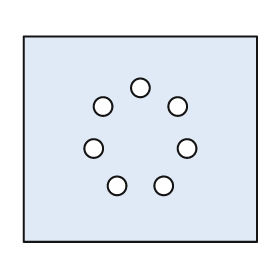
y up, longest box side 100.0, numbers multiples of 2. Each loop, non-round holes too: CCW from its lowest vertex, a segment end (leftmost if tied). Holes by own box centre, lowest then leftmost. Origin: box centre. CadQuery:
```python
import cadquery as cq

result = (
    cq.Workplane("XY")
    .moveTo(-50.0, -44.0)
    .lineTo(50.0, -44.0)
    .lineTo(50.0, 44.0)
    .lineTo(-50.0, 44.0)
    .close()
    .moveTo(-10.0, -20.0)
    .circle(4.0)
    .moveTo(10.0, -20.0)
    .circle(4.0)
    .moveTo(-20.0, -4.0)
    .circle(4.0)
    .moveTo(20.0, -4.0)
    .circle(4.0)
    .moveTo(-16.0, 14.0)
    .circle(4.0)
    .moveTo(16.0, 14.0)
    .circle(4.0)
    .moveTo(0.0, 22.0)
    .circle(4.0)
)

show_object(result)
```